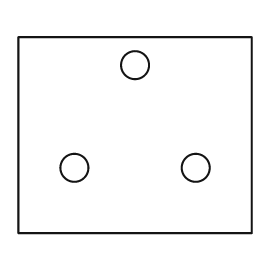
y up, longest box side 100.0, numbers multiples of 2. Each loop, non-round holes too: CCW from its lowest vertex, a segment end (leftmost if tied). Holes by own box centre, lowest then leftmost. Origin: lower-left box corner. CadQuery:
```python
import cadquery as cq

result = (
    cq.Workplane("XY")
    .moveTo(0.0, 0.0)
    .lineTo(100.0, 0.0)
    .lineTo(100.0, 84.0)
    .lineTo(0.0, 84.0)
    .close()
    .moveTo(24.0, 28.0)
    .circle(6.0)
    .moveTo(76.0, 28.0)
    .circle(6.0)
    .moveTo(50.0, 72.0)
    .circle(6.0)
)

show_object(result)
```